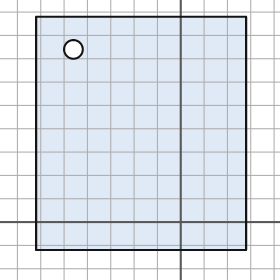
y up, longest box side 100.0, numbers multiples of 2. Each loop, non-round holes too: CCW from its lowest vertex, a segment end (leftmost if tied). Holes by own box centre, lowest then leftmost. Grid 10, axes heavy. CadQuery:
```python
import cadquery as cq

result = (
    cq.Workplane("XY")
    .moveTo(-62.0, -12.0)
    .lineTo(28.0, -12.0)
    .lineTo(28.0, 88.0)
    .lineTo(-62.0, 88.0)
    .close()
    .moveTo(-46.0, 74.0)
    .circle(4.0)
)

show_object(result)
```